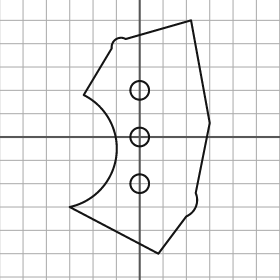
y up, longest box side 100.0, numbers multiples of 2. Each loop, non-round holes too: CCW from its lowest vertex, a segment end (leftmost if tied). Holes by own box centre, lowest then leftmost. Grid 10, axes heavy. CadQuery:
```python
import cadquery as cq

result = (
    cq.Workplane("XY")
    .moveTo(8.0, -50.0)
    .lineTo(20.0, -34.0)
    .threePointArc((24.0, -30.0), (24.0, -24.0))
    .lineTo(30.0, 6.0)
    .lineTo(22.0, 50.0)
    .lineTo(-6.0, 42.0)
    .threePointArc((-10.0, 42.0), (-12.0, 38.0))
    .lineTo(-24.0, 18.0)
    .threePointArc((-10.0, -8.0), (-30.0, -30.0))
    .close()
    .moveTo(0.0, -20.0)
    .circle(4.0)
    .moveTo(0.0, 0.0)
    .circle(4.0)
    .moveTo(0.0, 20.0)
    .circle(4.0)
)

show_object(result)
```